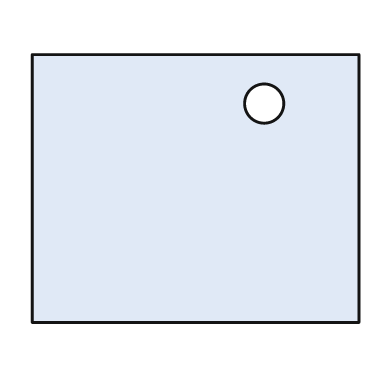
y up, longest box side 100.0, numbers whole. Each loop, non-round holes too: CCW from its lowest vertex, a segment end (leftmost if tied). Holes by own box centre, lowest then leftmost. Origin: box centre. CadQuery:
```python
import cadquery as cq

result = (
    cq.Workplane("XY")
    .moveTo(-50.0, -41.0)
    .lineTo(50.0, -41.0)
    .lineTo(50.0, 41.0)
    .lineTo(-50.0, 41.0)
    .close()
    .moveTo(21.0, 26.0)
    .circle(6.0)
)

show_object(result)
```